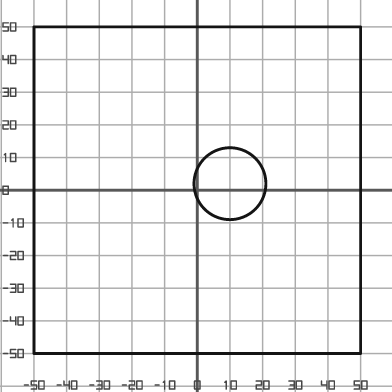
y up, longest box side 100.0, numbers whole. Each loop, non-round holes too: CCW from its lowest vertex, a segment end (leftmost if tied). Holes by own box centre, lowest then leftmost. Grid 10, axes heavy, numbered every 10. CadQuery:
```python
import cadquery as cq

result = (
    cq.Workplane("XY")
    .moveTo(-50.0, -50.0)
    .lineTo(50.0, -50.0)
    .lineTo(50.0, 50.0)
    .lineTo(-50.0, 50.0)
    .close()
    .moveTo(10.0, 2.0)
    .circle(11.0)
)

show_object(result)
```